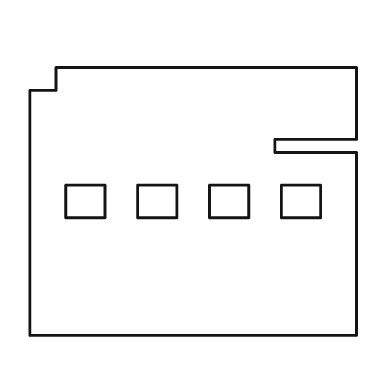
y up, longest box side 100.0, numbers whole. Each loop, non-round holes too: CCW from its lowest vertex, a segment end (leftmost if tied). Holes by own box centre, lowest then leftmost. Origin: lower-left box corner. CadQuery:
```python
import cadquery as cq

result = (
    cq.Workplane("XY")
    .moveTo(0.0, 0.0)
    .lineTo(100.0, 0.0)
    .lineTo(100.0, 56.0)
    .lineTo(75.0, 56.0)
    .lineTo(75.0, 60.0)
    .lineTo(100.0, 60.0)
    .lineTo(100.0, 82.0)
    .lineTo(8.0, 82.0)
    .lineTo(8.0, 75.0)
    .lineTo(0.0, 75.0)
    .close()
    .moveTo(11.0, 36.0)
    .lineTo(23.0, 36.0)
    .lineTo(23.0, 46.0)
    .lineTo(11.0, 46.0)
    .close()
    .moveTo(33.0, 36.0)
    .lineTo(45.0, 36.0)
    .lineTo(45.0, 46.0)
    .lineTo(33.0, 46.0)
    .close()
    .moveTo(55.0, 36.0)
    .lineTo(67.0, 36.0)
    .lineTo(67.0, 46.0)
    .lineTo(55.0, 46.0)
    .close()
    .moveTo(77.0, 36.0)
    .lineTo(89.0, 36.0)
    .lineTo(89.0, 46.0)
    .lineTo(77.0, 46.0)
    .close()
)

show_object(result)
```